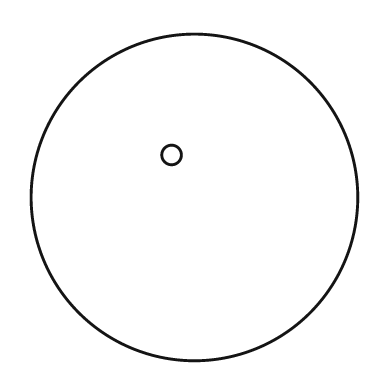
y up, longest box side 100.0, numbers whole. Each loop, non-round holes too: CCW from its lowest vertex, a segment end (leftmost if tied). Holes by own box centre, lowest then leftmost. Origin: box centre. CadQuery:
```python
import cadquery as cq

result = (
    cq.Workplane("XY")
    .moveTo(0.0, 0.0)
    .circle(50.0)
    .moveTo(-7.0, 13.0)
    .circle(3.0)
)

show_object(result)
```